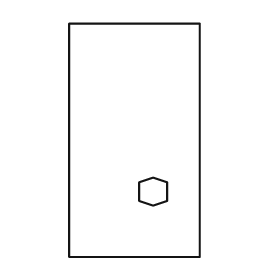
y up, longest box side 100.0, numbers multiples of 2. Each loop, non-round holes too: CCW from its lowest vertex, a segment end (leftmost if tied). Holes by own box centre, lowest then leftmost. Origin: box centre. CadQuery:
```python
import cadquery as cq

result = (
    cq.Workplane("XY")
    .moveTo(-28.0, -50.0)
    .lineTo(28.0, -50.0)
    .lineTo(28.0, 50.0)
    .lineTo(-28.0, 50.0)
    .close()
    .moveTo(8.0, -28.0)
    .lineTo(14.0, -26.0)
    .lineTo(14.0, -18.0)
    .lineTo(8.0, -16.0)
    .lineTo(2.0, -18.0)
    .lineTo(2.0, -26.0)
    .close()
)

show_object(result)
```